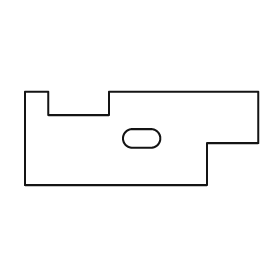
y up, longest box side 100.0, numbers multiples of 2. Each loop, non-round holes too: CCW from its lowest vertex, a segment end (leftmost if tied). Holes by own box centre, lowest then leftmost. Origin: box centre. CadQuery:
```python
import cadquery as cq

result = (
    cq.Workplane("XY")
    .moveTo(-50.0, -20.0)
    .lineTo(28.0, -20.0)
    .lineTo(28.0, -2.0)
    .lineTo(50.0, -2.0)
    .lineTo(50.0, 20.0)
    .lineTo(-14.0, 20.0)
    .lineTo(-14.0, 10.0)
    .lineTo(-40.0, 10.0)
    .lineTo(-40.0, 20.0)
    .lineTo(-50.0, 20.0)
    .close()
    .moveTo(-4.0, -4.0)
    .lineTo(4.0, -4.0)
    .threePointArc((8.0, 0.0), (4.0, 4.0))
    .lineTo(-4.0, 4.0)
    .threePointArc((-8.0, 0.0), (-4.0, -4.0))
    .close()
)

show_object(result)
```